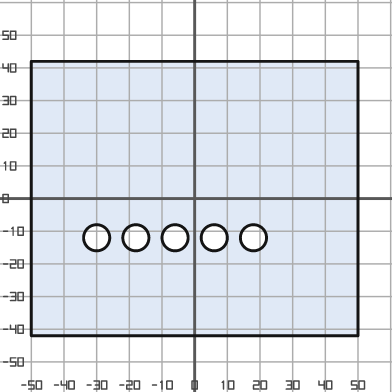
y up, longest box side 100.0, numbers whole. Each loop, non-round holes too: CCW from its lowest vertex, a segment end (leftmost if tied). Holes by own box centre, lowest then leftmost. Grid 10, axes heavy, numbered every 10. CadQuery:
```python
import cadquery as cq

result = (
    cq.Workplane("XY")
    .moveTo(-50.0, -42.0)
    .lineTo(50.0, -42.0)
    .lineTo(50.0, 42.0)
    .lineTo(-50.0, 42.0)
    .close()
    .moveTo(-30.0, -12.0)
    .circle(4.0)
    .moveTo(-18.0, -12.0)
    .circle(4.0)
    .moveTo(-6.0, -12.0)
    .circle(4.0)
    .moveTo(6.0, -12.0)
    .circle(4.0)
    .moveTo(18.0, -12.0)
    .circle(4.0)
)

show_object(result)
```